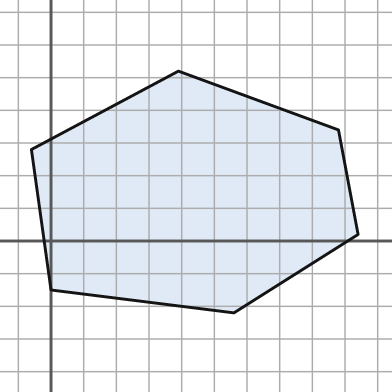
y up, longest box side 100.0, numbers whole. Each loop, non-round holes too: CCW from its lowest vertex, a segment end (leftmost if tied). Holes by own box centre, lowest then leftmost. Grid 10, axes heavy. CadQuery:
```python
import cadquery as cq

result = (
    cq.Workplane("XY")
    .moveTo(56.0, -22.0)
    .lineTo(94.0, 2.0)
    .lineTo(88.0, 34.0)
    .lineTo(39.0, 52.0)
    .lineTo(-6.0, 28.0)
    .lineTo(0.0, -15.0)
    .close()
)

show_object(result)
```